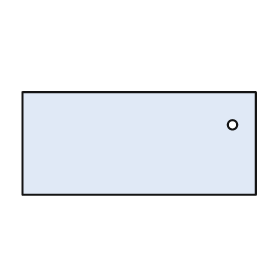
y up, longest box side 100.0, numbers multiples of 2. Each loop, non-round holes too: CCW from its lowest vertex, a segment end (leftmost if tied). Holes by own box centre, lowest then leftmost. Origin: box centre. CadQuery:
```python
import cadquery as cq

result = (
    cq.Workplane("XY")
    .moveTo(-50.0, -22.0)
    .lineTo(50.0, -22.0)
    .lineTo(50.0, 22.0)
    .lineTo(-50.0, 22.0)
    .close()
    .moveTo(40.0, 8.0)
    .circle(2.0)
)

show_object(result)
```